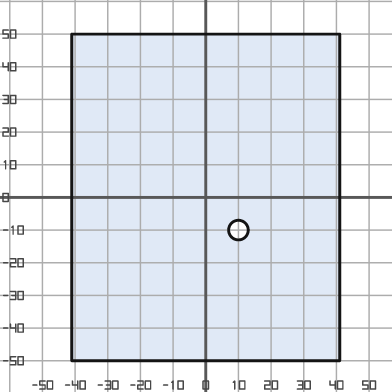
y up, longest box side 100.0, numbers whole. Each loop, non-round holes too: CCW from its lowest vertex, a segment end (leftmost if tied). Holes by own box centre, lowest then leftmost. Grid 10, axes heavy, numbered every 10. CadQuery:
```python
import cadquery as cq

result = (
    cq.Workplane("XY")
    .moveTo(-41.0, -50.0)
    .lineTo(41.0, -50.0)
    .lineTo(41.0, 50.0)
    .lineTo(-41.0, 50.0)
    .close()
    .moveTo(10.0, -10.0)
    .circle(3.0)
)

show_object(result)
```